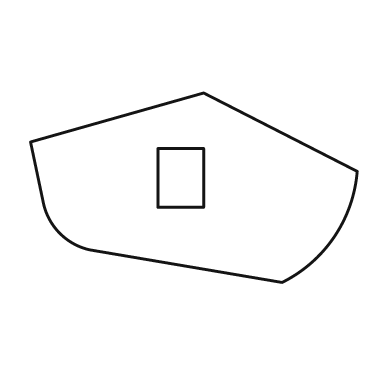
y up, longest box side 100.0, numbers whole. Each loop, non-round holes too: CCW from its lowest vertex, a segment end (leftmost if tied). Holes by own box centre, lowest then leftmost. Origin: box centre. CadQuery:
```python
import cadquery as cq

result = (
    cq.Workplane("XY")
    .moveTo(27.0, -29.0)
    .threePointArc((43.0, -15.0), (50.0, 5.0))
    .lineTo(3.0, 29.0)
    .lineTo(-50.0, 14.0)
    .lineTo(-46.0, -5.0)
    .threePointArc((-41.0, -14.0), (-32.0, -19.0))
    .close()
    .moveTo(-11.0, -6.0)
    .lineTo(3.0, -6.0)
    .lineTo(3.0, 12.0)
    .lineTo(-11.0, 12.0)
    .close()
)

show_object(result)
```